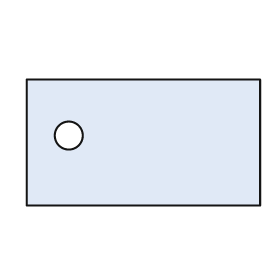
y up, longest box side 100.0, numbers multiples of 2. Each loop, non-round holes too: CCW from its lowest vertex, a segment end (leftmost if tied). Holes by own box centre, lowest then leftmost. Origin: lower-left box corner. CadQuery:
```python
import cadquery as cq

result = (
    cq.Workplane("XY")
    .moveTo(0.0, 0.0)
    .lineTo(100.0, 0.0)
    .lineTo(100.0, 54.0)
    .lineTo(0.0, 54.0)
    .close()
    .moveTo(18.0, 30.0)
    .circle(6.0)
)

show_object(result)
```